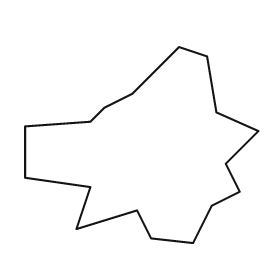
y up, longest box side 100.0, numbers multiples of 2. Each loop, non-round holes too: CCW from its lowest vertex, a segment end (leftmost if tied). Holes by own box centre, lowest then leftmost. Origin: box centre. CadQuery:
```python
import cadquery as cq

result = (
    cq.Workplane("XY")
    .moveTo(22.0, -42.0)
    .lineTo(30.0, -26.0)
    .lineTo(42.0, -20.0)
    .lineTo(36.0, -8.0)
    .lineTo(50.0, 6.0)
    .lineTo(32.0, 14.0)
    .lineTo(28.0, 38.0)
    .lineTo(16.0, 42.0)
    .lineTo(-4.0, 22.0)
    .lineTo(-16.0, 16.0)
    .lineTo(-22.0, 10.0)
    .lineTo(-50.0, 8.0)
    .lineTo(-50.0, -14.0)
    .lineTo(-22.0, -18.0)
    .lineTo(-28.0, -36.0)
    .lineTo(-2.0, -28.0)
    .lineTo(4.0, -40.0)
    .close()
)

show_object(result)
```